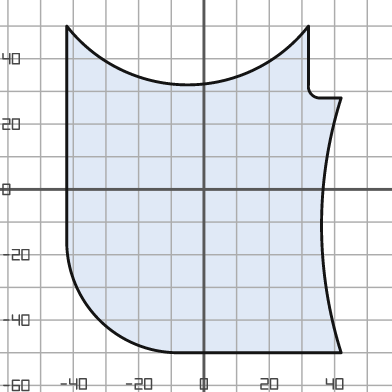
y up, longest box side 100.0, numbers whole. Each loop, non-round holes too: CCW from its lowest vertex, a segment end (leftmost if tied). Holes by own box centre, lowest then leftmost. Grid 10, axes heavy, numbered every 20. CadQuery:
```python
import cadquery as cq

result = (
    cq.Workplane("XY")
    .moveTo(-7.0, -50.0)
    .lineTo(42.0, -50.0)
    .threePointArc((36.0, -11.0), (42.0, 28.0))
    .lineTo(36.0, 28.0)
    .threePointArc((33.0, 29.0), (32.0, 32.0))
    .lineTo(32.0, 50.0)
    .threePointArc((-5.0, 32.0), (-42.0, 50.0))
    .lineTo(-42.0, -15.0)
    .threePointArc((-32.0, -40.0), (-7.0, -50.0))
    .close()
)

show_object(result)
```